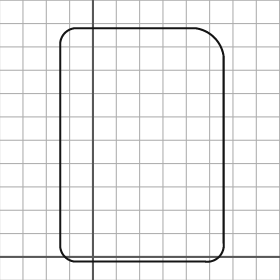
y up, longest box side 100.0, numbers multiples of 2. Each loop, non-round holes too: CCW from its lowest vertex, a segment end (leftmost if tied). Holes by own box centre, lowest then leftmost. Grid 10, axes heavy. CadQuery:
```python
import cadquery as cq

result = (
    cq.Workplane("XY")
    .moveTo(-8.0, -2.0)
    .lineTo(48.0, -2.0)
    .threePointArc((54.0, 0.0), (56.0, 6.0))
    .lineTo(56.0, 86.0)
    .threePointArc((52.0, 94.0), (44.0, 98.0))
    .lineTo(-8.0, 98.0)
    .threePointArc((-12.0, 96.0), (-14.0, 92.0))
    .lineTo(-14.0, 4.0)
    .threePointArc((-12.0, 0.0), (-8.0, -2.0))
    .close()
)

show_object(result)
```